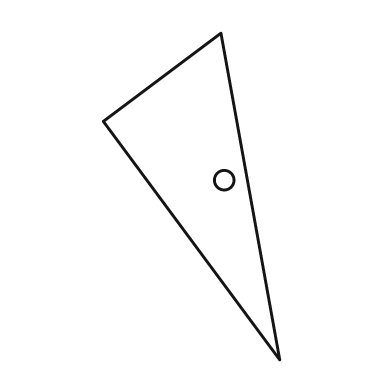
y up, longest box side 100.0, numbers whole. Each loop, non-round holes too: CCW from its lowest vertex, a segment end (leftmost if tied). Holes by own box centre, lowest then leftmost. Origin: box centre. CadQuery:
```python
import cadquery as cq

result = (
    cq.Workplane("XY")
    .moveTo(27.0, -50.0)
    .lineTo(9.0, 50.0)
    .lineTo(-27.0, 23.0)
    .close()
    .moveTo(10.0, 5.0)
    .circle(3.0)
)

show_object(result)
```